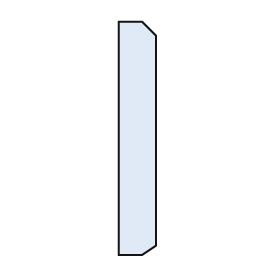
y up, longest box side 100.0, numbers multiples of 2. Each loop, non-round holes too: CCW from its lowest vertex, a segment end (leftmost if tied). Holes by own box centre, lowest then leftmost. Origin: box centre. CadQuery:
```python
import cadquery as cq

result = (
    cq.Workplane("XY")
    .moveTo(-8.0, -50.0)
    .lineTo(2.0, -50.0)
    .lineTo(8.0, -46.0)
    .lineTo(8.0, 44.0)
    .lineTo(2.0, 50.0)
    .lineTo(-8.0, 50.0)
    .close()
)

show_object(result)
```